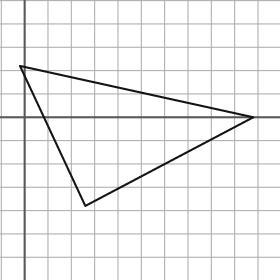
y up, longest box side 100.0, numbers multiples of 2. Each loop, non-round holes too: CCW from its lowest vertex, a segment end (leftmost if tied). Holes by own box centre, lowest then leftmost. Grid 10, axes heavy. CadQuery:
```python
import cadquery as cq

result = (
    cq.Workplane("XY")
    .moveTo(26.0, -38.0)
    .lineTo(98.0, 0.0)
    .lineTo(-2.0, 22.0)
    .close()
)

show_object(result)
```